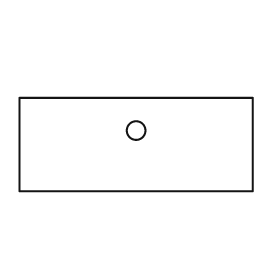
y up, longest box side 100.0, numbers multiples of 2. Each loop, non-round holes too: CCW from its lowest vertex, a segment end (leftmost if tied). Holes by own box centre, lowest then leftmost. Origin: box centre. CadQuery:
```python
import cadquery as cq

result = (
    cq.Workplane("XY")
    .moveTo(-50.0, -20.0)
    .lineTo(50.0, -20.0)
    .lineTo(50.0, 20.0)
    .lineTo(-50.0, 20.0)
    .close()
    .moveTo(0.0, 6.0)
    .circle(4.0)
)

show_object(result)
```